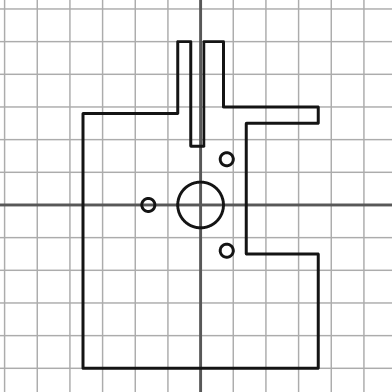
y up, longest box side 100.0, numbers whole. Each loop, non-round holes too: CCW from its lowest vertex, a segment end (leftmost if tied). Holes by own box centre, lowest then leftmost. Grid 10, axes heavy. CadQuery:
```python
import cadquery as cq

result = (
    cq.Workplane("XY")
    .moveTo(-36.0, -50.0)
    .lineTo(36.0, -50.0)
    .lineTo(36.0, -15.0)
    .lineTo(14.0, -15.0)
    .lineTo(14.0, 25.0)
    .lineTo(36.0, 25.0)
    .lineTo(36.0, 30.0)
    .lineTo(7.0, 30.0)
    .lineTo(7.0, 50.0)
    .lineTo(1.0, 50.0)
    .lineTo(1.0, 18.0)
    .lineTo(-3.0, 18.0)
    .lineTo(-3.0, 50.0)
    .lineTo(-7.0, 50.0)
    .lineTo(-7.0, 28.0)
    .lineTo(-36.0, 28.0)
    .close()
    .moveTo(8.0, -14.0)
    .circle(2.0)
    .moveTo(-16.0, 0.0)
    .circle(2.0)
    .moveTo(0.0, 0.0)
    .circle(7.0)
    .moveTo(8.0, 14.0)
    .circle(2.0)
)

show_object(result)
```